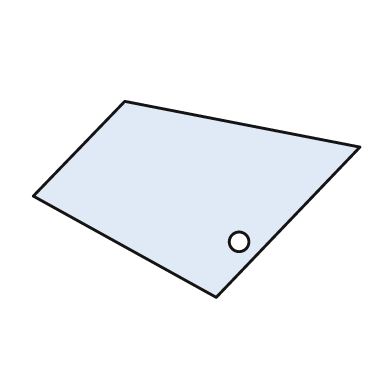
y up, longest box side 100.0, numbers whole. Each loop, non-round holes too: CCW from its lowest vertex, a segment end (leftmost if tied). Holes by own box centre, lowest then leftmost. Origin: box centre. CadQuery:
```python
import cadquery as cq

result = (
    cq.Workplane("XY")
    .moveTo(6.0, -30.0)
    .lineTo(50.0, 16.0)
    .lineTo(-22.0, 30.0)
    .lineTo(-50.0, 1.0)
    .close()
    .moveTo(13.0, -13.0)
    .circle(3.0)
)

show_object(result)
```